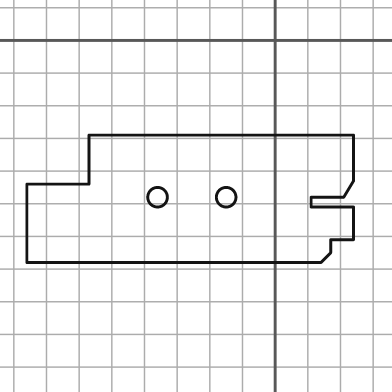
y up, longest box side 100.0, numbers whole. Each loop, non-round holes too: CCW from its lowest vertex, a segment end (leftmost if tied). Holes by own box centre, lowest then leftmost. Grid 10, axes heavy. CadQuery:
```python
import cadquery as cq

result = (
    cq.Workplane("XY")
    .moveTo(-76.0, -68.0)
    .lineTo(14.0, -68.0)
    .lineTo(17.0, -65.0)
    .lineTo(17.0, -61.0)
    .lineTo(24.0, -61.0)
    .lineTo(24.0, -51.0)
    .lineTo(11.0, -51.0)
    .lineTo(11.0, -48.0)
    .lineTo(21.0, -48.0)
    .lineTo(24.0, -43.0)
    .lineTo(24.0, -29.0)
    .lineTo(-57.0, -29.0)
    .lineTo(-57.0, -44.0)
    .lineTo(-76.0, -44.0)
    .close()
    .moveTo(-36.0, -48.0)
    .circle(3.0)
    .moveTo(-15.0, -48.0)
    .circle(3.0)
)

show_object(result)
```